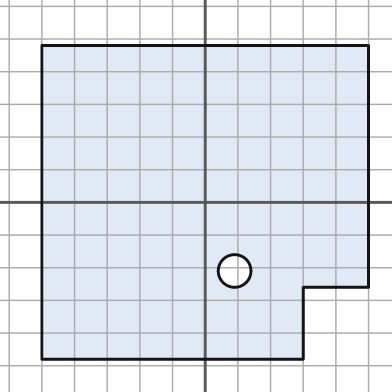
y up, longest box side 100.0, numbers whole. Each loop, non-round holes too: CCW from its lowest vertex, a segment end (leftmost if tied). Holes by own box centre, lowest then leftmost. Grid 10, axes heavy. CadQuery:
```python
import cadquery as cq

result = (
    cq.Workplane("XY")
    .moveTo(-50.0, -48.0)
    .lineTo(30.0, -48.0)
    .lineTo(30.0, -26.0)
    .lineTo(50.0, -26.0)
    .lineTo(50.0, 48.0)
    .lineTo(-50.0, 48.0)
    .close()
    .moveTo(9.0, -21.0)
    .circle(5.0)
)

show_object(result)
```